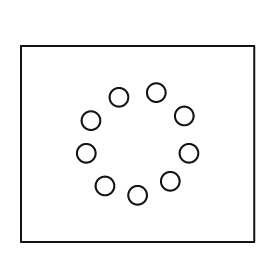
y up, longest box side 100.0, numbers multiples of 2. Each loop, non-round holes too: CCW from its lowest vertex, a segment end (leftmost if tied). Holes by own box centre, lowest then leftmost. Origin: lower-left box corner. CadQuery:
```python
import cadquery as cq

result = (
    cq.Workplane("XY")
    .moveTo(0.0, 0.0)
    .lineTo(100.0, 0.0)
    .lineTo(100.0, 84.0)
    .lineTo(0.0, 84.0)
    .close()
    .moveTo(50.0, 20.0)
    .circle(4.0)
    .moveTo(36.0, 24.0)
    .circle(4.0)
    .moveTo(64.0, 26.0)
    .circle(4.0)
    .moveTo(28.0, 38.0)
    .circle(4.0)
    .moveTo(72.0, 38.0)
    .circle(4.0)
    .moveTo(30.0, 52.0)
    .circle(4.0)
    .moveTo(70.0, 54.0)
    .circle(4.0)
    .moveTo(42.0, 62.0)
    .circle(4.0)
    .moveTo(58.0, 64.0)
    .circle(4.0)
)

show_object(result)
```